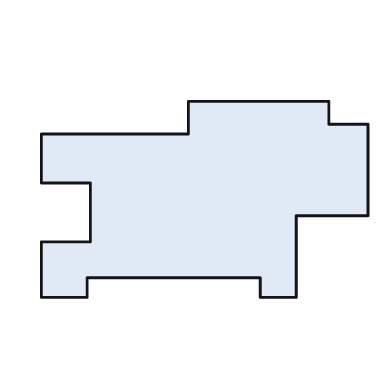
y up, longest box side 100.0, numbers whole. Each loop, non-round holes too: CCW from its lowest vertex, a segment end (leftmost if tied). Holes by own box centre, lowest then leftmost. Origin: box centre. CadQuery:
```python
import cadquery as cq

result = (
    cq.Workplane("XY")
    .moveTo(-50.0, -30.0)
    .lineTo(-36.0, -30.0)
    .lineTo(-36.0, -24.0)
    .lineTo(17.0, -24.0)
    .lineTo(17.0, -30.0)
    .lineTo(28.0, -30.0)
    .lineTo(28.0, -5.0)
    .lineTo(50.0, -5.0)
    .lineTo(50.0, 23.0)
    .lineTo(38.0, 23.0)
    .lineTo(38.0, 30.0)
    .lineTo(-5.0, 30.0)
    .lineTo(-5.0, 20.0)
    .lineTo(-50.0, 20.0)
    .lineTo(-50.0, 5.0)
    .lineTo(-35.0, 5.0)
    .lineTo(-35.0, -13.0)
    .lineTo(-50.0, -13.0)
    .close()
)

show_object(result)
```